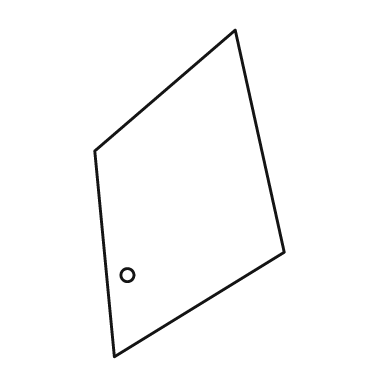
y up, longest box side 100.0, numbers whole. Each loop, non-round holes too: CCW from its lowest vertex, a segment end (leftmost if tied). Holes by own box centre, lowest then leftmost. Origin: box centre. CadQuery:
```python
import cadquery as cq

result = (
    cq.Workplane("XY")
    .moveTo(-23.0, -50.0)
    .lineTo(29.0, -18.0)
    .lineTo(14.0, 50.0)
    .lineTo(-29.0, 13.0)
    .close()
    .moveTo(-19.0, -25.0)
    .circle(2.0)
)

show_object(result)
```